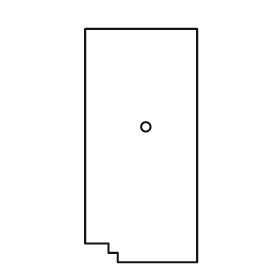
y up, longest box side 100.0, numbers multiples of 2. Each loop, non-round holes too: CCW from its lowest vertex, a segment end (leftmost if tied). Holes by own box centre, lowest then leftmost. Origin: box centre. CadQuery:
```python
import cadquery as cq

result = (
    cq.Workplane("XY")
    .moveTo(-10.0, -50.0)
    .lineTo(24.0, -50.0)
    .lineTo(24.0, 50.0)
    .lineTo(-24.0, 50.0)
    .lineTo(-24.0, -42.0)
    .lineTo(-14.0, -42.0)
    .lineTo(-14.0, -46.0)
    .lineTo(-10.0, -46.0)
    .close()
    .moveTo(2.0, 8.0)
    .circle(2.0)
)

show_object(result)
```